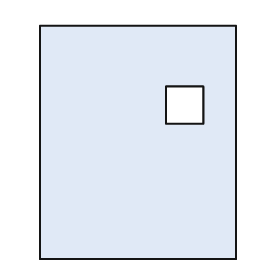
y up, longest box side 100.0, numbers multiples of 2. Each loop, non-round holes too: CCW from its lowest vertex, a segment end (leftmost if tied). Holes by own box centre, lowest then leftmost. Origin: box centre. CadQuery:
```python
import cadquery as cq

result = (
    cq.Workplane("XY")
    .moveTo(-42.0, -50.0)
    .lineTo(42.0, -50.0)
    .lineTo(42.0, 50.0)
    .lineTo(-42.0, 50.0)
    .close()
    .moveTo(12.0, 8.0)
    .lineTo(28.0, 8.0)
    .lineTo(28.0, 24.0)
    .lineTo(12.0, 24.0)
    .close()
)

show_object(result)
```